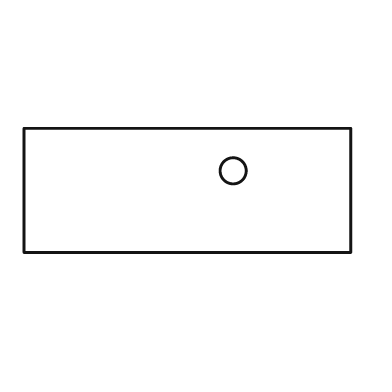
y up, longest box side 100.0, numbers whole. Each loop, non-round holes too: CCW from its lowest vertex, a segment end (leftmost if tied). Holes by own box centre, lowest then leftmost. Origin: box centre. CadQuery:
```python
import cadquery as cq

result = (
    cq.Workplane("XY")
    .moveTo(-50.0, -19.0)
    .lineTo(50.0, -19.0)
    .lineTo(50.0, 19.0)
    .lineTo(-50.0, 19.0)
    .close()
    .moveTo(14.0, 6.0)
    .circle(4.0)
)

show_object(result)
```